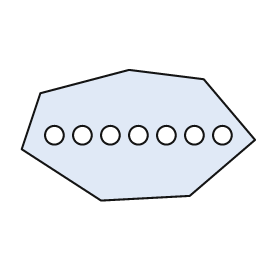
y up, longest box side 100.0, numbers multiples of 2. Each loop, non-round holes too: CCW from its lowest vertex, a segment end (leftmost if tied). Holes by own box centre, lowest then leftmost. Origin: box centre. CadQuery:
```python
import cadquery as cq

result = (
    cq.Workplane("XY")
    .moveTo(-16.0, -28.0)
    .lineTo(22.0, -26.0)
    .lineTo(50.0, -2.0)
    .lineTo(28.0, 24.0)
    .lineTo(-4.0, 28.0)
    .lineTo(-42.0, 18.0)
    .lineTo(-50.0, -6.0)
    .close()
    .moveTo(-36.0, 0.0)
    .circle(4.0)
    .moveTo(-24.0, 0.0)
    .circle(4.0)
    .moveTo(-12.0, 0.0)
    .circle(4.0)
    .moveTo(0.0, 0.0)
    .circle(4.0)
    .moveTo(12.0, 0.0)
    .circle(4.0)
    .moveTo(24.0, 0.0)
    .circle(4.0)
    .moveTo(36.0, 0.0)
    .circle(4.0)
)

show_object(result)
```